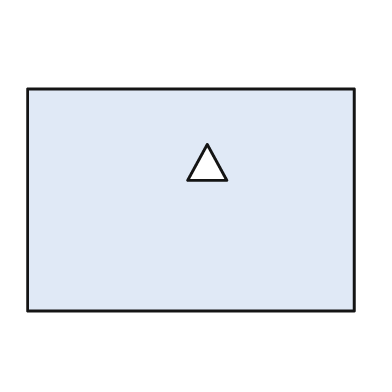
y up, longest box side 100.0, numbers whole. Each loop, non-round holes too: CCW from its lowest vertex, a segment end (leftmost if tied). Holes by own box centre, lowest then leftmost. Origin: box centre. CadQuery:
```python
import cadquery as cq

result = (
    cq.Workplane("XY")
    .moveTo(-50.0, -34.0)
    .lineTo(50.0, -34.0)
    .lineTo(50.0, 34.0)
    .lineTo(-50.0, 34.0)
    .close()
    .moveTo(-1.0, 6.0)
    .lineTo(11.0, 6.0)
    .lineTo(5.0, 17.0)
    .close()
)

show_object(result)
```